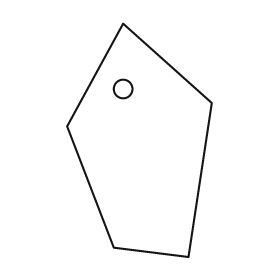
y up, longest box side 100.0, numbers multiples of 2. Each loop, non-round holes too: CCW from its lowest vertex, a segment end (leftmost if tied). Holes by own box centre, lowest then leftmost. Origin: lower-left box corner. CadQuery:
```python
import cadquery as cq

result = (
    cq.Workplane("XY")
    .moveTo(52.0, 0.0)
    .lineTo(62.0, 66.0)
    .lineTo(24.0, 100.0)
    .lineTo(0.0, 56.0)
    .lineTo(20.0, 4.0)
    .close()
    .moveTo(24.0, 72.0)
    .circle(4.0)
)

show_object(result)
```